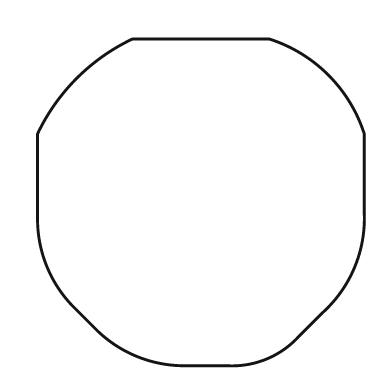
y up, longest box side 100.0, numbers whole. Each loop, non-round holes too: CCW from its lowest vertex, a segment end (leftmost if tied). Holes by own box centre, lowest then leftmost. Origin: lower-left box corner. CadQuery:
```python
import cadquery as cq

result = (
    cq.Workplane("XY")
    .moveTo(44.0, 0.0)
    .lineTo(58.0, 0.0)
    .threePointArc((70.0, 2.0), (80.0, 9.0))
    .lineTo(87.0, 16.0)
    .threePointArc((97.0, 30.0), (100.0, 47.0))
    .lineTo(100.0, 71.0)
    .threePointArc((89.0, 89.0), (71.0, 100.0))
    .lineTo(29.0, 100.0)
    .threePointArc((12.0, 88.0), (0.0, 71.0))
    .lineTo(0.0, 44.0)
    .threePointArc((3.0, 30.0), (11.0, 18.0))
    .lineTo(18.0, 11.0)
    .threePointArc((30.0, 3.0), (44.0, 0.0))
    .close()
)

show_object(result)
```